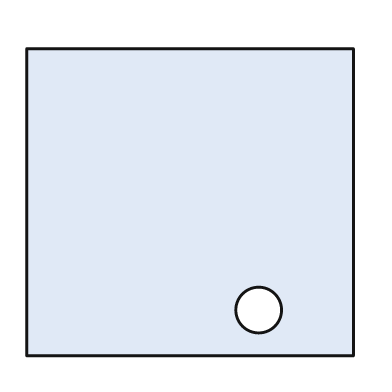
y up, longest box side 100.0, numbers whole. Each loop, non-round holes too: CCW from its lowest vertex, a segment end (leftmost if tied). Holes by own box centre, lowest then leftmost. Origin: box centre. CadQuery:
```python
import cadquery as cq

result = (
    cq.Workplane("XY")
    .moveTo(-50.0, -47.0)
    .lineTo(50.0, -47.0)
    .lineTo(50.0, 47.0)
    .lineTo(-50.0, 47.0)
    .close()
    .moveTo(21.0, -33.0)
    .circle(7.0)
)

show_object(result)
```